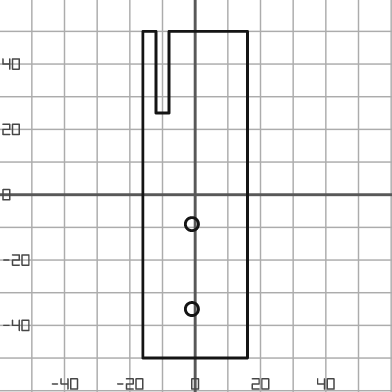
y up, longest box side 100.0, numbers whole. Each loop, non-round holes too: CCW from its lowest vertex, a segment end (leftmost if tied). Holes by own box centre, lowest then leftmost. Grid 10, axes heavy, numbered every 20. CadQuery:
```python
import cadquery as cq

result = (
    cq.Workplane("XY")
    .moveTo(-16.0, -50.0)
    .lineTo(16.0, -50.0)
    .lineTo(16.0, 50.0)
    .lineTo(-8.0, 50.0)
    .lineTo(-8.0, 25.0)
    .lineTo(-12.0, 25.0)
    .lineTo(-12.0, 50.0)
    .lineTo(-16.0, 50.0)
    .close()
    .moveTo(-1.0, -35.0)
    .circle(2.0)
    .moveTo(-1.0, -9.0)
    .circle(2.0)
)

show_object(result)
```